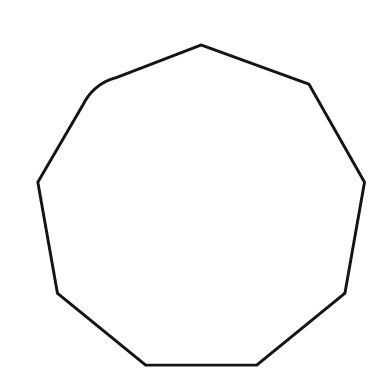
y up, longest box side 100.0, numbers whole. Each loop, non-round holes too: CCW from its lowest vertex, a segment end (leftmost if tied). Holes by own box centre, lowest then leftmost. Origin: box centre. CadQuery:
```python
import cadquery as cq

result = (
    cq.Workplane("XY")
    .moveTo(-17.0, -49.0)
    .lineTo(17.0, -49.0)
    .lineTo(44.0, -27.0)
    .lineTo(50.0, 7.0)
    .lineTo(33.0, 37.0)
    .lineTo(0.0, 49.0)
    .lineTo(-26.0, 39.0)
    .threePointArc((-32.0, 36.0), (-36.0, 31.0))
    .lineTo(-50.0, 7.0)
    .lineTo(-44.0, -27.0)
    .close()
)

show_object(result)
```